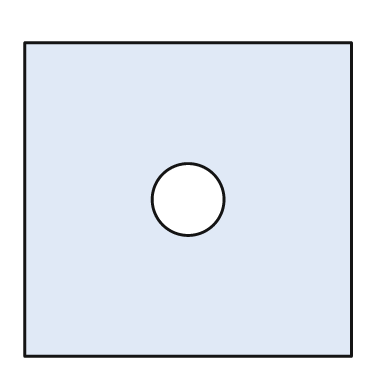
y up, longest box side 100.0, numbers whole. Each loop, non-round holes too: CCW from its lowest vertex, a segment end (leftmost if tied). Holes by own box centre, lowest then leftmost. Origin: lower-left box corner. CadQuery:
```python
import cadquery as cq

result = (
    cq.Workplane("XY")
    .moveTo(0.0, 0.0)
    .lineTo(100.0, 0.0)
    .lineTo(100.0, 96.0)
    .lineTo(0.0, 96.0)
    .close()
    .moveTo(50.0, 48.0)
    .circle(11.0)
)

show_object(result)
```